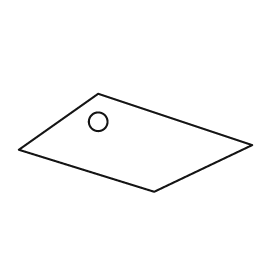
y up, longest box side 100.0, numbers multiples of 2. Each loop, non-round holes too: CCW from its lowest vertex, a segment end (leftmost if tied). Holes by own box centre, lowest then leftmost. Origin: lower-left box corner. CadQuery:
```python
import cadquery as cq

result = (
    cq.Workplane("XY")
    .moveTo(58.0, 0.0)
    .lineTo(100.0, 20.0)
    .lineTo(34.0, 42.0)
    .lineTo(0.0, 18.0)
    .close()
    .moveTo(34.0, 30.0)
    .circle(4.0)
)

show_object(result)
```